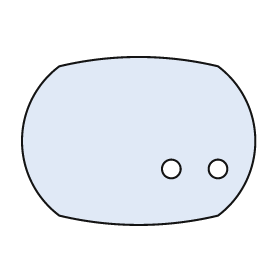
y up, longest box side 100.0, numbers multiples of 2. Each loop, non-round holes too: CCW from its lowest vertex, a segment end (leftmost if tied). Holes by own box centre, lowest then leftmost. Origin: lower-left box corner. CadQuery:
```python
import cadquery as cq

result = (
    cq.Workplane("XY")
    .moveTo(16.0, 4.0)
    .threePointArc((50.0, 0.0), (84.0, 4.0))
    .threePointArc((100.0, 36.0), (84.0, 68.0))
    .threePointArc((50.0, 72.0), (16.0, 68.0))
    .threePointArc((0.0, 36.0), (16.0, 4.0))
    .close()
    .moveTo(64.0, 24.0)
    .circle(4.0)
    .moveTo(84.0, 24.0)
    .circle(4.0)
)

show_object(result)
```